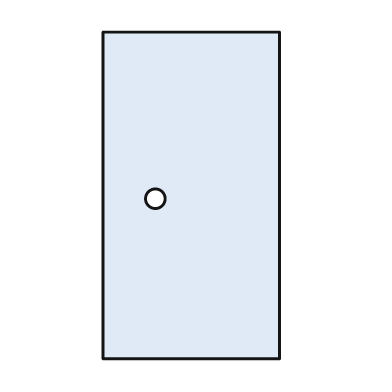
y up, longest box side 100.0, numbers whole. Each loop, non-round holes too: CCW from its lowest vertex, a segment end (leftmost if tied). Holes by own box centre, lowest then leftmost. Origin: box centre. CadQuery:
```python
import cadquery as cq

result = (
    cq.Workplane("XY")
    .moveTo(-27.0, -50.0)
    .lineTo(27.0, -50.0)
    .lineTo(27.0, 50.0)
    .lineTo(-27.0, 50.0)
    .close()
    .moveTo(-11.0, -1.0)
    .circle(3.0)
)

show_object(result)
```